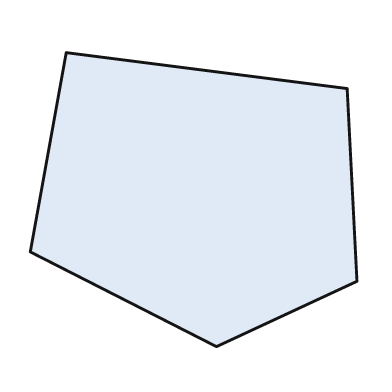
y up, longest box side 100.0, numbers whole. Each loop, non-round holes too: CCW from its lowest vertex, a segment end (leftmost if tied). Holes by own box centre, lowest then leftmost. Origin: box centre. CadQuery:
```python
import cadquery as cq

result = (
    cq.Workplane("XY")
    .moveTo(7.0, -45.0)
    .lineTo(50.0, -25.0)
    .lineTo(47.0, 34.0)
    .lineTo(-39.0, 45.0)
    .lineTo(-50.0, -16.0)
    .close()
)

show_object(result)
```